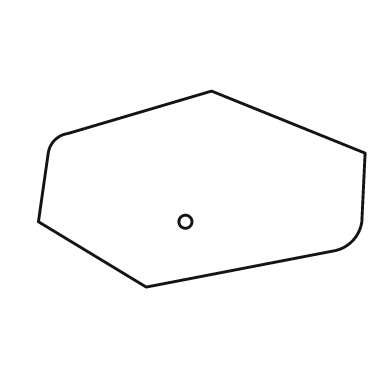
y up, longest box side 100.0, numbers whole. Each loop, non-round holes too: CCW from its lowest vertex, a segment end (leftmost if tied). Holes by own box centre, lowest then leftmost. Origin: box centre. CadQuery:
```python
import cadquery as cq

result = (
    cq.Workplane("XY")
    .moveTo(-17.0, -30.0)
    .lineTo(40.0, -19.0)
    .threePointArc((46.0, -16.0), (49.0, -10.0))
    .lineTo(50.0, 11.0)
    .lineTo(3.0, 30.0)
    .lineTo(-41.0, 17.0)
    .threePointArc((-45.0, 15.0), (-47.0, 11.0))
    .lineTo(-50.0, -10.0)
    .close()
    .moveTo(-5.0, -10.0)
    .circle(2.0)
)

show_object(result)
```